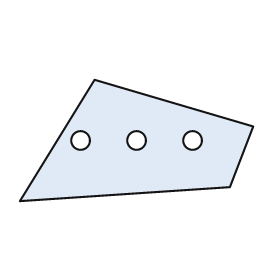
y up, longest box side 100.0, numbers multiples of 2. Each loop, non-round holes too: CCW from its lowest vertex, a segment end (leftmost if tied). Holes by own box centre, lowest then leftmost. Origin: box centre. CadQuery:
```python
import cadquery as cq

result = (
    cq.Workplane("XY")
    .moveTo(-50.0, -26.0)
    .lineTo(40.0, -20.0)
    .lineTo(50.0, 6.0)
    .lineTo(-18.0, 26.0)
    .close()
    .moveTo(-24.0, 0.0)
    .circle(4.0)
    .moveTo(0.0, 0.0)
    .circle(4.0)
    .moveTo(24.0, 0.0)
    .circle(4.0)
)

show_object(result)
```